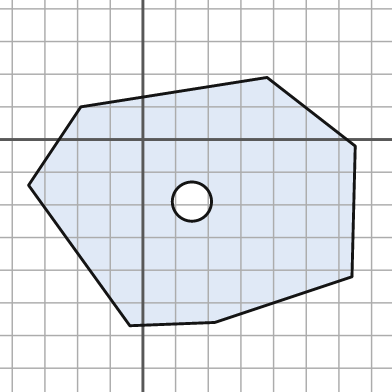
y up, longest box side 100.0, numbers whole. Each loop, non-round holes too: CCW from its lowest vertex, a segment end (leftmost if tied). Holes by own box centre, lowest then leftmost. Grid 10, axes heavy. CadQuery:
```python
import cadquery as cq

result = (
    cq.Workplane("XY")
    .moveTo(-4.0, -57.0)
    .lineTo(22.0, -56.0)
    .lineTo(64.0, -42.0)
    .lineTo(65.0, -2.0)
    .lineTo(38.0, 19.0)
    .lineTo(-19.0, 10.0)
    .lineTo(-35.0, -14.0)
    .close()
    .moveTo(15.0, -19.0)
    .circle(6.0)
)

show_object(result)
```